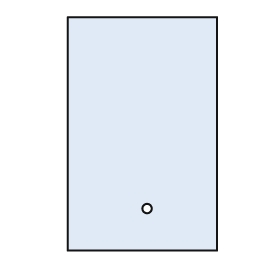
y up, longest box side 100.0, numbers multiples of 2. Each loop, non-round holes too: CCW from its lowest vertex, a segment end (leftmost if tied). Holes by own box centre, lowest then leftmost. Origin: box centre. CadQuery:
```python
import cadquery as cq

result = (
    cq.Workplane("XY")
    .moveTo(-32.0, -50.0)
    .lineTo(32.0, -50.0)
    .lineTo(32.0, 50.0)
    .lineTo(-32.0, 50.0)
    .close()
    .moveTo(2.0, -32.0)
    .circle(2.0)
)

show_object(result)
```